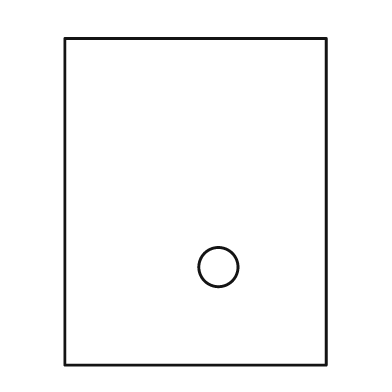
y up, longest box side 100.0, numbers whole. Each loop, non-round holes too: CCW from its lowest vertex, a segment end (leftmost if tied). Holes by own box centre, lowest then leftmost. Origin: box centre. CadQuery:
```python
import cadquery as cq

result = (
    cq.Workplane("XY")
    .moveTo(-40.0, -50.0)
    .lineTo(40.0, -50.0)
    .lineTo(40.0, 50.0)
    .lineTo(-40.0, 50.0)
    .close()
    .moveTo(7.0, -20.0)
    .circle(6.0)
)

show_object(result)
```